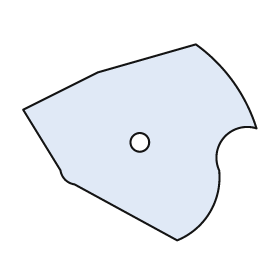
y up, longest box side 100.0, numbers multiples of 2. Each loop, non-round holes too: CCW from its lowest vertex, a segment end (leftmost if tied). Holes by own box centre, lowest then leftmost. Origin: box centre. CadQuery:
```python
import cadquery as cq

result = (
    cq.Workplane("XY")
    .moveTo(16.0, -42.0)
    .threePointArc((30.0, -30.0), (34.0, -12.0))
    .threePointArc((36.0, 2.0), (50.0, 6.0))
    .threePointArc((40.0, 26.0), (24.0, 42.0))
    .lineTo(-18.0, 30.0)
    .lineTo(-50.0, 14.0)
    .lineTo(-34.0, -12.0)
    .threePointArc((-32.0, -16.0), (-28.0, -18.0))
    .close()
    .moveTo(0.0, 0.0)
    .circle(4.0)
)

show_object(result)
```